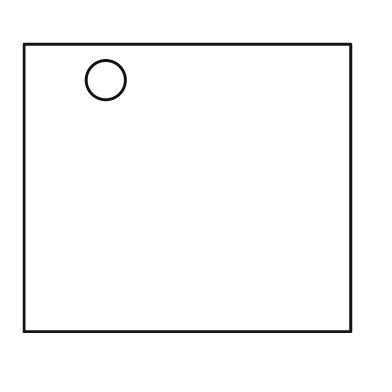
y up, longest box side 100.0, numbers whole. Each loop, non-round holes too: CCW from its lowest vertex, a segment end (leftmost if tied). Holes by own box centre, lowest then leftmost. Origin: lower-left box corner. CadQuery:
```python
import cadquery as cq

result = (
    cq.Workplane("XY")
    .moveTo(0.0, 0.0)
    .lineTo(100.0, 0.0)
    .lineTo(100.0, 88.0)
    .lineTo(0.0, 88.0)
    .close()
    .moveTo(25.0, 77.0)
    .circle(6.0)
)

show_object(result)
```